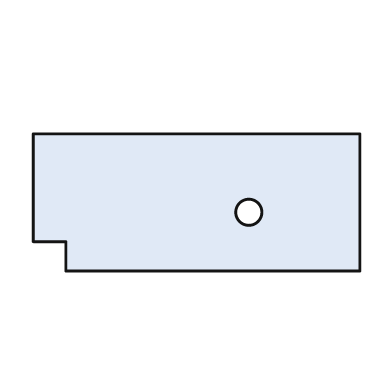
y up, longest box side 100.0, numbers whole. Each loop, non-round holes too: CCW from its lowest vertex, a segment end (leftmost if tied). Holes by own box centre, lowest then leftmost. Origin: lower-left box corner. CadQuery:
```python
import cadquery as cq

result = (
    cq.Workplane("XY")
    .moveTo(10.0, 0.0)
    .lineTo(100.0, 0.0)
    .lineTo(100.0, 42.0)
    .lineTo(0.0, 42.0)
    .lineTo(0.0, 9.0)
    .lineTo(10.0, 9.0)
    .close()
    .moveTo(66.0, 18.0)
    .circle(4.0)
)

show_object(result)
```